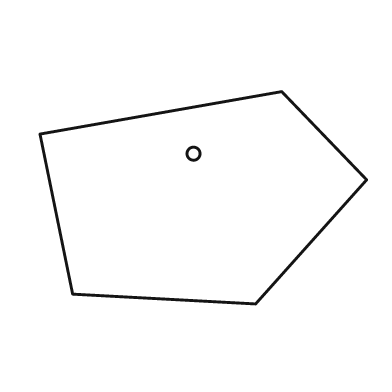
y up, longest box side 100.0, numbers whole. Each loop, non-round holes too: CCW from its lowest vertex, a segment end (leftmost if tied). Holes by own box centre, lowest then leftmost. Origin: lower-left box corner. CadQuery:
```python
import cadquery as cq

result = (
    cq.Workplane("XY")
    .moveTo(66.0, 0.0)
    .lineTo(100.0, 38.0)
    .lineTo(74.0, 65.0)
    .lineTo(0.0, 52.0)
    .lineTo(10.0, 3.0)
    .close()
    .moveTo(47.0, 46.0)
    .circle(2.0)
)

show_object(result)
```